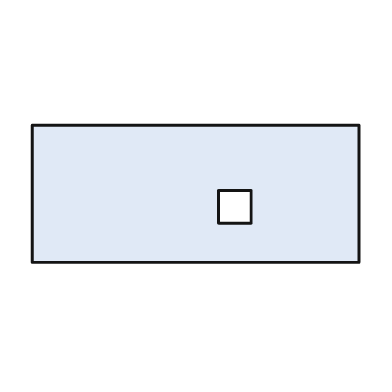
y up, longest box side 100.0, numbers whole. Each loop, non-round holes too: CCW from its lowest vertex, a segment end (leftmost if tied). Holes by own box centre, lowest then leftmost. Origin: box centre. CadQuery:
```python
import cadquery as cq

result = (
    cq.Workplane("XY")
    .moveTo(-50.0, -21.0)
    .lineTo(50.0, -21.0)
    .lineTo(50.0, 21.0)
    .lineTo(-50.0, 21.0)
    .close()
    .moveTo(7.0, -9.0)
    .lineTo(17.0, -9.0)
    .lineTo(17.0, 1.0)
    .lineTo(7.0, 1.0)
    .close()
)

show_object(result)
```